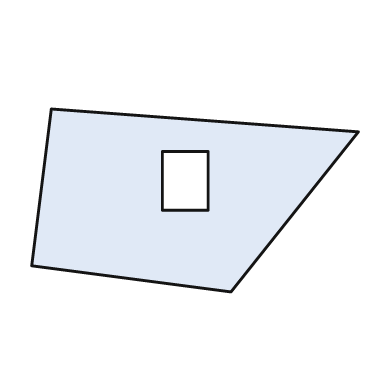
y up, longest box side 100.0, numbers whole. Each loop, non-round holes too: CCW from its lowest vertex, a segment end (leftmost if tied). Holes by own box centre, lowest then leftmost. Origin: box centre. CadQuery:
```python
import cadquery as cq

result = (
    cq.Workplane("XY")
    .moveTo(11.0, -28.0)
    .lineTo(50.0, 21.0)
    .lineTo(-44.0, 28.0)
    .lineTo(-50.0, -20.0)
    .close()
    .moveTo(-10.0, -3.0)
    .lineTo(4.0, -3.0)
    .lineTo(4.0, 15.0)
    .lineTo(-10.0, 15.0)
    .close()
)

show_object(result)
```